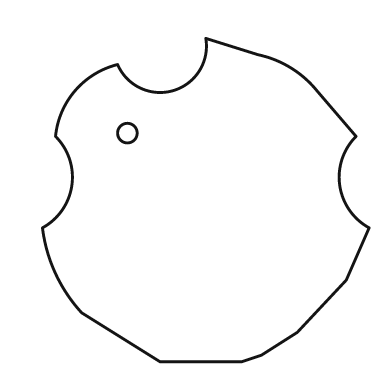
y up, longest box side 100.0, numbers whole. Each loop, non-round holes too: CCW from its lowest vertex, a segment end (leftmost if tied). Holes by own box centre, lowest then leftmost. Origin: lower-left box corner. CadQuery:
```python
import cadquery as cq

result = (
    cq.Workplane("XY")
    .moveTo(36.0, 0.0)
    .lineTo(61.0, 0.0)
    .lineTo(67.0, 2.0)
    .lineTo(78.0, 9.0)
    .lineTo(93.0, 25.0)
    .lineTo(100.0, 41.0)
    .threePointArc((91.0, 54.0), (96.0, 69.0))
    .lineTo(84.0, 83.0)
    .threePointArc((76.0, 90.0), (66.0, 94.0))
    .lineTo(50.0, 99.0)
    .threePointArc((40.0, 83.0), (23.0, 91.0))
    .threePointArc((10.0, 83.0), (4.0, 69.0))
    .threePointArc((9.0, 54.0), (0.0, 41.0))
    .threePointArc((4.0, 27.0), (12.0, 15.0))
    .close()
    .moveTo(26.0, 70.0)
    .circle(3.0)
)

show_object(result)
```